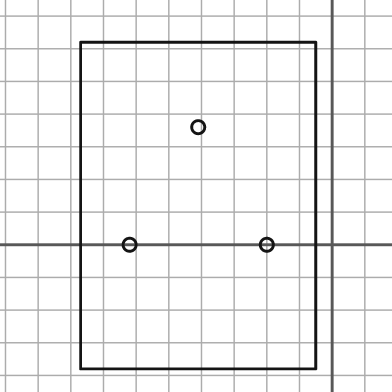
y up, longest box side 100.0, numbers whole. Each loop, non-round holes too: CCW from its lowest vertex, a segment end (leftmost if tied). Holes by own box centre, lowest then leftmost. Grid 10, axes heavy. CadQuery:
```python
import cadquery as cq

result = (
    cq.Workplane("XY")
    .moveTo(-77.0, -38.0)
    .lineTo(-5.0, -38.0)
    .lineTo(-5.0, 62.0)
    .lineTo(-77.0, 62.0)
    .close()
    .moveTo(-62.0, 0.0)
    .circle(2.0)
    .moveTo(-20.0, 0.0)
    .circle(2.0)
    .moveTo(-41.0, 36.0)
    .circle(2.0)
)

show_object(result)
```